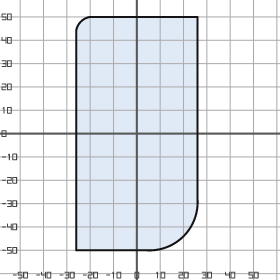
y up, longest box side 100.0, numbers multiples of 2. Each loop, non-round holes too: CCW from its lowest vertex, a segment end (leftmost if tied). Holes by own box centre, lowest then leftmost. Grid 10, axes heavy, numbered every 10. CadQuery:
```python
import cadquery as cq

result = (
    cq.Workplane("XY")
    .moveTo(-26.0, -50.0)
    .lineTo(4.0, -50.0)
    .threePointArc((20.0, -44.0), (26.0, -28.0))
    .lineTo(26.0, 50.0)
    .lineTo(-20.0, 50.0)
    .threePointArc((-24.0, 48.0), (-26.0, 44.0))
    .close()
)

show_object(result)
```